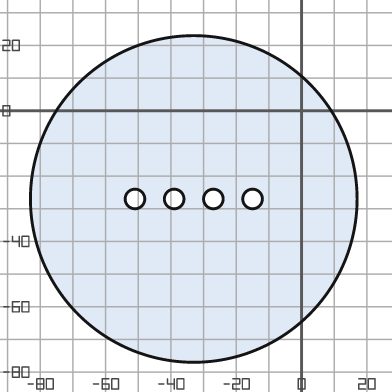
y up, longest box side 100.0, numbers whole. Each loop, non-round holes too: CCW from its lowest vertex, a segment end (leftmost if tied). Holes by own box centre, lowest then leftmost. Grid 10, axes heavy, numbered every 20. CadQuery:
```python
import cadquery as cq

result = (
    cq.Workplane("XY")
    .moveTo(-33.0, -27.0)
    .circle(50.0)
    .moveTo(-51.0, -27.0)
    .circle(3.0)
    .moveTo(-39.0, -27.0)
    .circle(3.0)
    .moveTo(-27.0, -27.0)
    .circle(3.0)
    .moveTo(-15.0, -27.0)
    .circle(3.0)
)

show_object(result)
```